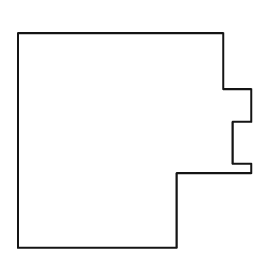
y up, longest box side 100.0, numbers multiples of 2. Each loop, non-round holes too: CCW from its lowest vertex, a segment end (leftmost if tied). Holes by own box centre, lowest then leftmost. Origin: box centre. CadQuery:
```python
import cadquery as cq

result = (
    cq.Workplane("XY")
    .moveTo(-50.0, -46.0)
    .lineTo(18.0, -46.0)
    .lineTo(18.0, -14.0)
    .lineTo(50.0, -14.0)
    .lineTo(50.0, -10.0)
    .lineTo(42.0, -10.0)
    .lineTo(42.0, 8.0)
    .lineTo(50.0, 8.0)
    .lineTo(50.0, 22.0)
    .lineTo(38.0, 22.0)
    .lineTo(38.0, 46.0)
    .lineTo(-50.0, 46.0)
    .close()
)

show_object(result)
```